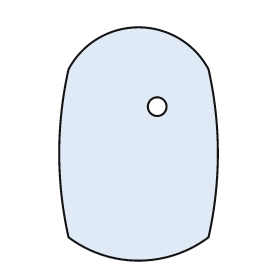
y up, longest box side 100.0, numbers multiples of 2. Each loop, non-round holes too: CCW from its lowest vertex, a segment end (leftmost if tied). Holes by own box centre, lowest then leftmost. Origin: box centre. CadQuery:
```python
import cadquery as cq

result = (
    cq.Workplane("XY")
    .moveTo(-30.0, -40.0)
    .threePointArc((0.0, -50.0), (30.0, -40.0))
    .threePointArc((34.0, -4.0), (30.0, 32.0))
    .threePointArc((0.0, 50.0), (-30.0, 32.0))
    .threePointArc((-34.0, -4.0), (-30.0, -40.0))
    .close()
    .moveTo(8.0, 16.0)
    .circle(4.0)
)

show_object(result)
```